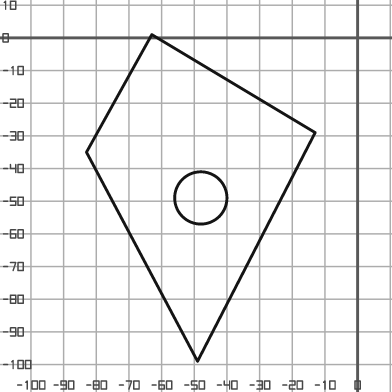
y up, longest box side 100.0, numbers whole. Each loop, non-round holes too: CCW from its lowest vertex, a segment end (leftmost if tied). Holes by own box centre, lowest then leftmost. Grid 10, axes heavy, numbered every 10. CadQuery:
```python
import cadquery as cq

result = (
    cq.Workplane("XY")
    .moveTo(-49.0, -99.0)
    .lineTo(-13.0, -29.0)
    .lineTo(-63.0, 1.0)
    .lineTo(-83.0, -35.0)
    .close()
    .moveTo(-48.0, -49.0)
    .circle(8.0)
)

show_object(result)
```